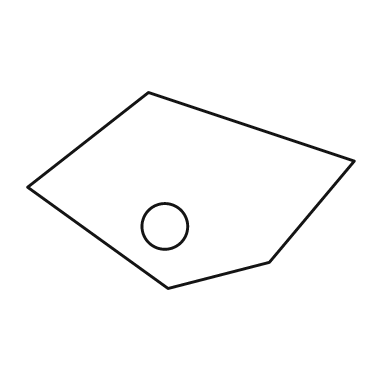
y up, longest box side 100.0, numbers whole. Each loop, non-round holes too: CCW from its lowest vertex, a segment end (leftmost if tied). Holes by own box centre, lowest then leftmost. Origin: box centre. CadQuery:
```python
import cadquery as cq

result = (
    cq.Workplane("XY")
    .moveTo(-7.0, -30.0)
    .lineTo(24.0, -22.0)
    .lineTo(50.0, 9.0)
    .lineTo(-13.0, 30.0)
    .lineTo(-50.0, 1.0)
    .close()
    .moveTo(-8.0, -11.0)
    .circle(7.0)
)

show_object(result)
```